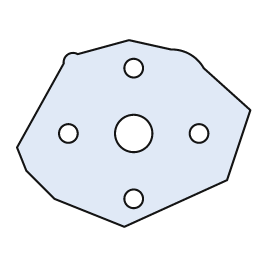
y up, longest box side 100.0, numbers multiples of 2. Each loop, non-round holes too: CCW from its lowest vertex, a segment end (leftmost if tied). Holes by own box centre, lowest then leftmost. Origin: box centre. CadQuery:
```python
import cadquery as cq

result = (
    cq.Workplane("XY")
    .moveTo(-4.0, -40.0)
    .lineTo(40.0, -20.0)
    .lineTo(50.0, 10.0)
    .lineTo(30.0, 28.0)
    .threePointArc((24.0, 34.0), (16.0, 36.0))
    .lineTo(-2.0, 40.0)
    .lineTo(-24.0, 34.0)
    .threePointArc((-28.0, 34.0), (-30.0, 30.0))
    .lineTo(-50.0, -6.0)
    .lineTo(-46.0, -16.0)
    .lineTo(-34.0, -28.0)
    .close()
    .moveTo(0.0, -28.0)
    .circle(4.0)
    .moveTo(-28.0, 0.0)
    .circle(4.0)
    .moveTo(0.0, 0.0)
    .circle(8.0)
    .moveTo(28.0, 0.0)
    .circle(4.0)
    .moveTo(0.0, 28.0)
    .circle(4.0)
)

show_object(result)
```